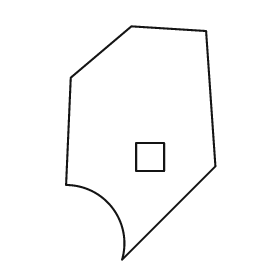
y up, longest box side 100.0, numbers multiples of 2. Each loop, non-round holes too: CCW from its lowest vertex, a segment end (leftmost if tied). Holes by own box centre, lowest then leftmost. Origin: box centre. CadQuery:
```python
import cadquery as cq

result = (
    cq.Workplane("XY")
    .moveTo(-8.0, -50.0)
    .lineTo(32.0, -10.0)
    .lineTo(28.0, 48.0)
    .lineTo(-4.0, 50.0)
    .lineTo(-30.0, 28.0)
    .lineTo(-32.0, -18.0)
    .threePointArc((-12.0, -28.0), (-8.0, -50.0))
    .close()
    .moveTo(-2.0, -12.0)
    .lineTo(10.0, -12.0)
    .lineTo(10.0, 0.0)
    .lineTo(-2.0, 0.0)
    .close()
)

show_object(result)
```